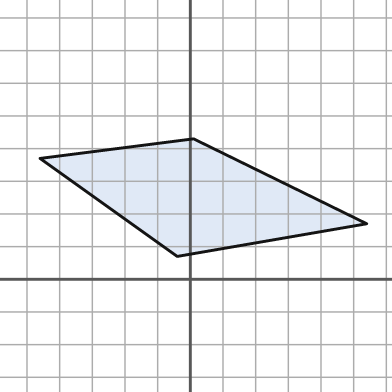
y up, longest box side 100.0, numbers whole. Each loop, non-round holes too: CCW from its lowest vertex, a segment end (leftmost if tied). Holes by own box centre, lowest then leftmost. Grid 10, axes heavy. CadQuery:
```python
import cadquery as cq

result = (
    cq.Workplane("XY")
    .moveTo(-4.0, 7.0)
    .lineTo(54.0, 17.0)
    .lineTo(1.0, 43.0)
    .lineTo(-46.0, 37.0)
    .close()
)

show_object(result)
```